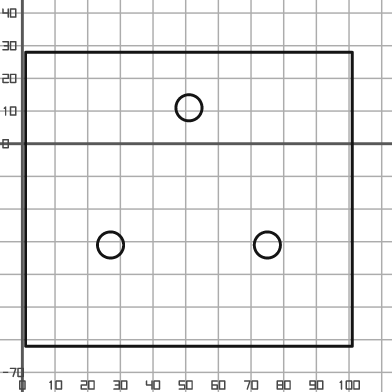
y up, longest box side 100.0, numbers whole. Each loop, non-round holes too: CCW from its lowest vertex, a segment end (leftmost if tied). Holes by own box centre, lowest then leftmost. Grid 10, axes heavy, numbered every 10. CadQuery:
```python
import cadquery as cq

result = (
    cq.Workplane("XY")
    .moveTo(1.0, -62.0)
    .lineTo(101.0, -62.0)
    .lineTo(101.0, 28.0)
    .lineTo(1.0, 28.0)
    .close()
    .moveTo(27.0, -31.0)
    .circle(4.0)
    .moveTo(75.0, -31.0)
    .circle(4.0)
    .moveTo(51.0, 11.0)
    .circle(4.0)
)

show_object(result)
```